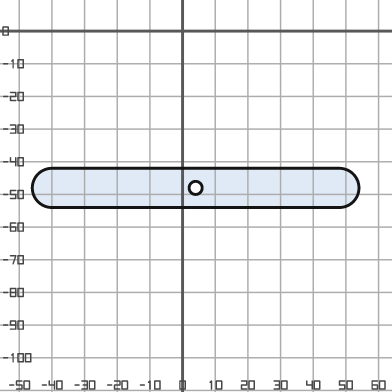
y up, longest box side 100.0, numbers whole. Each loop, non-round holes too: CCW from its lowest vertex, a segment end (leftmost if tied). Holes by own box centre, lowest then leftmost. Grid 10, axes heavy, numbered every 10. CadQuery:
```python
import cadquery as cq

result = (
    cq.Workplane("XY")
    .moveTo(-40.0, -54.0)
    .lineTo(48.0, -54.0)
    .threePointArc((54.0, -48.0), (48.0, -42.0))
    .lineTo(-40.0, -42.0)
    .threePointArc((-46.0, -48.0), (-40.0, -54.0))
    .close()
    .moveTo(4.0, -48.0)
    .circle(2.0)
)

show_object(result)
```